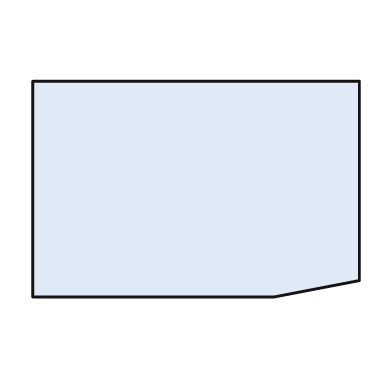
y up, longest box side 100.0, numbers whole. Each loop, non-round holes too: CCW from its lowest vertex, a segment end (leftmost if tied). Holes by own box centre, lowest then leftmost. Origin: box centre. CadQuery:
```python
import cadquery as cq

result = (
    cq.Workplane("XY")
    .moveTo(-50.0, -33.0)
    .lineTo(24.0, -33.0)
    .lineTo(50.0, -28.0)
    .lineTo(50.0, 33.0)
    .lineTo(-50.0, 33.0)
    .close()
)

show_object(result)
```